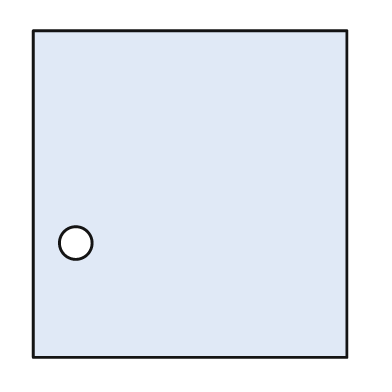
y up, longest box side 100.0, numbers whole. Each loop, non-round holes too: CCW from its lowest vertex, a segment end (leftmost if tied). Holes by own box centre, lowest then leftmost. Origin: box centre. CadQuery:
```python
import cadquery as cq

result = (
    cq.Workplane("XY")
    .moveTo(-48.0, -50.0)
    .lineTo(48.0, -50.0)
    .lineTo(48.0, 50.0)
    .lineTo(-48.0, 50.0)
    .close()
    .moveTo(-35.0, -15.0)
    .circle(5.0)
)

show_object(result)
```